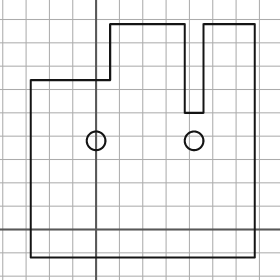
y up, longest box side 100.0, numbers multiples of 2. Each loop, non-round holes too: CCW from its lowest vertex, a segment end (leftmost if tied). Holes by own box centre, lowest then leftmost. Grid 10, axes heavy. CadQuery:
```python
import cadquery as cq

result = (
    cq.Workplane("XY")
    .moveTo(-28.0, -12.0)
    .lineTo(68.0, -12.0)
    .lineTo(68.0, 88.0)
    .lineTo(46.0, 88.0)
    .lineTo(46.0, 50.0)
    .lineTo(38.0, 50.0)
    .lineTo(38.0, 88.0)
    .lineTo(6.0, 88.0)
    .lineTo(6.0, 64.0)
    .lineTo(-28.0, 64.0)
    .close()
    .moveTo(0.0, 38.0)
    .circle(4.0)
    .moveTo(42.0, 38.0)
    .circle(4.0)
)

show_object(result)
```